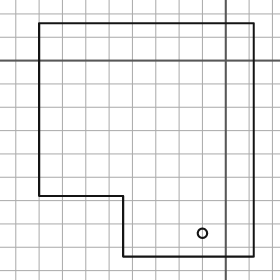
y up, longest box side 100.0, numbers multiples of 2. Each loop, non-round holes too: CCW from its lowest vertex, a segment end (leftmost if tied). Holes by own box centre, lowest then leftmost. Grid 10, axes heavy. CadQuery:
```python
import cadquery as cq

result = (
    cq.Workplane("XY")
    .moveTo(-44.0, -84.0)
    .lineTo(12.0, -84.0)
    .lineTo(12.0, 16.0)
    .lineTo(-80.0, 16.0)
    .lineTo(-80.0, -58.0)
    .lineTo(-44.0, -58.0)
    .close()
    .moveTo(-10.0, -74.0)
    .circle(2.0)
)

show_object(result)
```